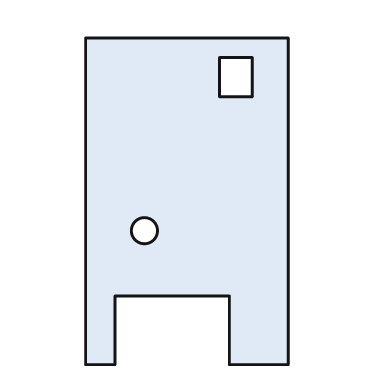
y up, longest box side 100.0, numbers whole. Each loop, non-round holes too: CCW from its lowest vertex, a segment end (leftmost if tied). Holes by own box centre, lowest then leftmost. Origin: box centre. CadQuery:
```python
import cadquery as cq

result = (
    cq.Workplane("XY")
    .moveTo(-31.0, -50.0)
    .lineTo(-22.0, -50.0)
    .lineTo(-22.0, -29.0)
    .lineTo(13.0, -29.0)
    .lineTo(13.0, -50.0)
    .lineTo(31.0, -50.0)
    .lineTo(31.0, 50.0)
    .lineTo(-31.0, 50.0)
    .close()
    .moveTo(-13.0, -9.0)
    .circle(4.0)
    .moveTo(10.0, 32.0)
    .lineTo(20.0, 32.0)
    .lineTo(20.0, 44.0)
    .lineTo(10.0, 44.0)
    .close()
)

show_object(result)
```